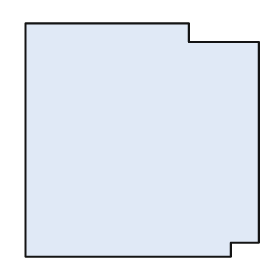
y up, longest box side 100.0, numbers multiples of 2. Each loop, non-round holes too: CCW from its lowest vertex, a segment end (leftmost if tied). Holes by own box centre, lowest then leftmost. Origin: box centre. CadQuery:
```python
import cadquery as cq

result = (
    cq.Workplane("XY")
    .moveTo(-50.0, -50.0)
    .lineTo(38.0, -50.0)
    .lineTo(38.0, -44.0)
    .lineTo(50.0, -44.0)
    .lineTo(50.0, 42.0)
    .lineTo(20.0, 42.0)
    .lineTo(20.0, 50.0)
    .lineTo(-50.0, 50.0)
    .close()
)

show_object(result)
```